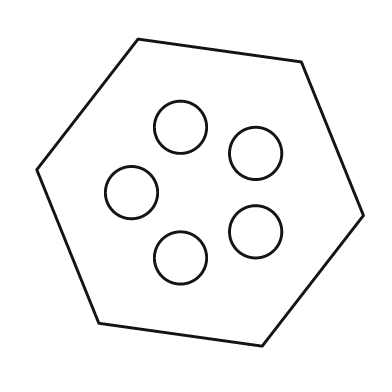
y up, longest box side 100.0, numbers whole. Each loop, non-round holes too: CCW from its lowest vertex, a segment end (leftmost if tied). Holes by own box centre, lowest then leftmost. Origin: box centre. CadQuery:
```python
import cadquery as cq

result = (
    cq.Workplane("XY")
    .moveTo(19.0, -47.0)
    .lineTo(50.0, -7.0)
    .lineTo(31.0, 40.0)
    .lineTo(-19.0, 47.0)
    .lineTo(-50.0, 7.0)
    .lineTo(-31.0, -40.0)
    .close()
    .moveTo(-6.0, -20.0)
    .circle(8.0)
    .moveTo(17.0, -12.0)
    .circle(8.0)
    .moveTo(-21.0, 0.0)
    .circle(8.0)
    .moveTo(17.0, 12.0)
    .circle(8.0)
    .moveTo(-6.0, 20.0)
    .circle(8.0)
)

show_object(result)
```